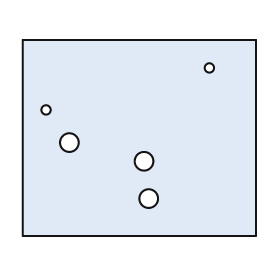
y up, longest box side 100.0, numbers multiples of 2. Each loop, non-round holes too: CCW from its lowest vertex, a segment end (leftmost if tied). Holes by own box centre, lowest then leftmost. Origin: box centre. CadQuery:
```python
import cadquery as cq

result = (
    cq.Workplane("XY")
    .moveTo(-50.0, -42.0)
    .lineTo(50.0, -42.0)
    .lineTo(50.0, 42.0)
    .lineTo(-50.0, 42.0)
    .close()
    .moveTo(4.0, -26.0)
    .circle(4.0)
    .moveTo(2.0, -10.0)
    .circle(4.0)
    .moveTo(-30.0, -2.0)
    .circle(4.0)
    .moveTo(-40.0, 12.0)
    .circle(2.0)
    .moveTo(30.0, 30.0)
    .circle(2.0)
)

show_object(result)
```